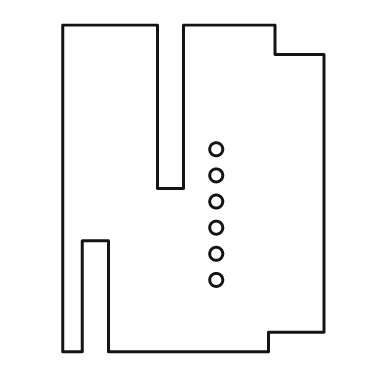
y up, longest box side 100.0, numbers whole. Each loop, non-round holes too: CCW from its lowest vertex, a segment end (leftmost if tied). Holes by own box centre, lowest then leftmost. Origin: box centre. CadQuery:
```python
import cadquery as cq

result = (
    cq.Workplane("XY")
    .moveTo(-40.0, -50.0)
    .lineTo(-34.0, -50.0)
    .lineTo(-34.0, -16.0)
    .lineTo(-26.0, -16.0)
    .lineTo(-26.0, -50.0)
    .lineTo(23.0, -50.0)
    .lineTo(23.0, -44.0)
    .lineTo(40.0, -44.0)
    .lineTo(40.0, 41.0)
    .lineTo(25.0, 41.0)
    .lineTo(25.0, 50.0)
    .lineTo(-3.0, 50.0)
    .lineTo(-3.0, 0.0)
    .lineTo(-11.0, 0.0)
    .lineTo(-11.0, 50.0)
    .lineTo(-40.0, 50.0)
    .close()
    .moveTo(7.0, -28.0)
    .circle(2.0)
    .moveTo(7.0, -20.0)
    .circle(2.0)
    .moveTo(7.0, -12.0)
    .circle(2.0)
    .moveTo(7.0, -4.0)
    .circle(2.0)
    .moveTo(7.0, 4.0)
    .circle(2.0)
    .moveTo(7.0, 12.0)
    .circle(2.0)
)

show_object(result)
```